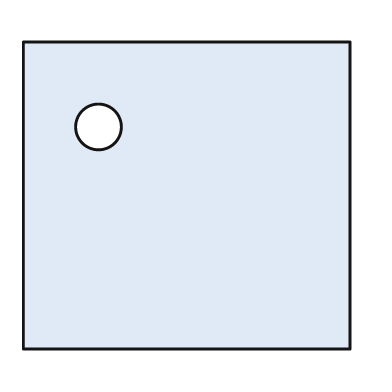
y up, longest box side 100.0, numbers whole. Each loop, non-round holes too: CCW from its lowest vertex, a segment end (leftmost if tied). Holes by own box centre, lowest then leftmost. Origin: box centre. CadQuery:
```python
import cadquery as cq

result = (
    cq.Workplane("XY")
    .moveTo(-50.0, -47.0)
    .lineTo(50.0, -47.0)
    .lineTo(50.0, 47.0)
    .lineTo(-50.0, 47.0)
    .close()
    .moveTo(-27.0, 21.0)
    .circle(7.0)
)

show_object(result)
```